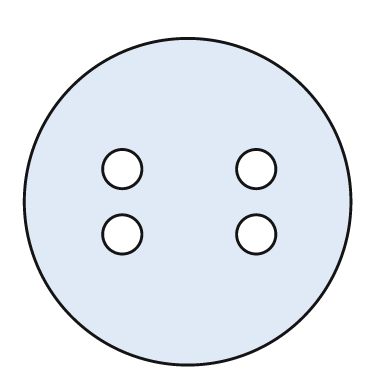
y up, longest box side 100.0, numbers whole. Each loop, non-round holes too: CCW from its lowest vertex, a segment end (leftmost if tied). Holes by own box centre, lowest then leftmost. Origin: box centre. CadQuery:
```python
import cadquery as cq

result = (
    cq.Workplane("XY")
    .moveTo(0.0, 0.0)
    .circle(50.0)
    .moveTo(-20.0, -10.0)
    .circle(6.0)
    .moveTo(21.0, -10.0)
    .circle(6.0)
    .moveTo(-20.0, 10.0)
    .circle(6.0)
    .moveTo(21.0, 10.0)
    .circle(6.0)
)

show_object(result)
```